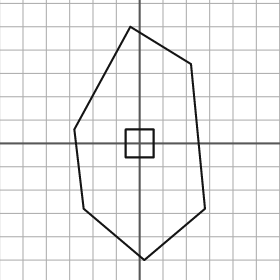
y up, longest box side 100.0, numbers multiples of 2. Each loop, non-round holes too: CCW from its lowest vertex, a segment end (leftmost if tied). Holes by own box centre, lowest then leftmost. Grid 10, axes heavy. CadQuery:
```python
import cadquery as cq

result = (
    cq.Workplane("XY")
    .moveTo(2.0, -50.0)
    .lineTo(28.0, -28.0)
    .lineTo(22.0, 34.0)
    .lineTo(-4.0, 50.0)
    .lineTo(-28.0, 6.0)
    .lineTo(-24.0, -28.0)
    .close()
    .moveTo(-6.0, -6.0)
    .lineTo(6.0, -6.0)
    .lineTo(6.0, 6.0)
    .lineTo(-6.0, 6.0)
    .close()
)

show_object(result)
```